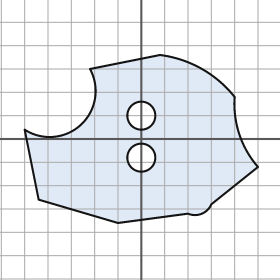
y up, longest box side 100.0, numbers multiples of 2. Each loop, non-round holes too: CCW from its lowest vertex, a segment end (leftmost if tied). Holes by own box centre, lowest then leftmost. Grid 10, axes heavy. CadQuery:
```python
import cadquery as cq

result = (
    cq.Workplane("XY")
    .moveTo(-10.0, -36.0)
    .lineTo(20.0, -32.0)
    .threePointArc((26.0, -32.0), (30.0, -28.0))
    .lineTo(50.0, -12.0)
    .threePointArc((42.0, 2.0), (40.0, 18.0))
    .threePointArc((26.0, 30.0), (8.0, 36.0))
    .lineTo(-22.0, 30.0)
    .threePointArc((-26.0, 6.0), (-50.0, 4.0))
    .lineTo(-44.0, -26.0)
    .close()
    .moveTo(0.0, -8.0)
    .circle(6.0)
    .moveTo(0.0, 10.0)
    .circle(6.0)
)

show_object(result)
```